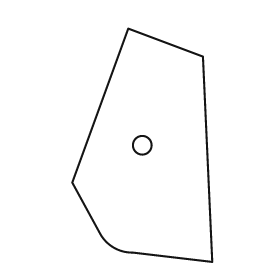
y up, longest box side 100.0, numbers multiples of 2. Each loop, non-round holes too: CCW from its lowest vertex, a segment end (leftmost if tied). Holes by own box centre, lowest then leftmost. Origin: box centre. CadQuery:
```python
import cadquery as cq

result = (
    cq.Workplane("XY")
    .moveTo(30.0, -50.0)
    .lineTo(26.0, 38.0)
    .lineTo(-6.0, 50.0)
    .lineTo(-30.0, -16.0)
    .lineTo(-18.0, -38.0)
    .threePointArc((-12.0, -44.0), (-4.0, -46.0))
    .close()
    .moveTo(0.0, 0.0)
    .circle(4.0)
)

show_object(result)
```